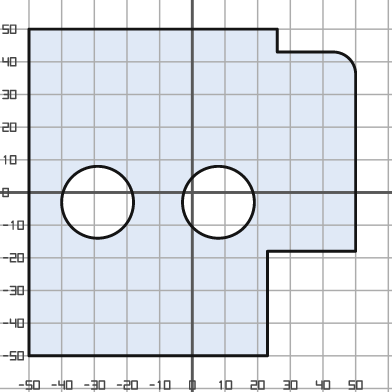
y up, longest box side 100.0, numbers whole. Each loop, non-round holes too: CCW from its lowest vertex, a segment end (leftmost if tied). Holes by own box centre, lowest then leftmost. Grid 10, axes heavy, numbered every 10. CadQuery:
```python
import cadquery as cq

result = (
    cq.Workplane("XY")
    .moveTo(-50.0, -50.0)
    .lineTo(23.0, -50.0)
    .lineTo(23.0, -18.0)
    .lineTo(50.0, -18.0)
    .lineTo(50.0, 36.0)
    .threePointArc((48.0, 41.0), (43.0, 43.0))
    .lineTo(26.0, 43.0)
    .lineTo(26.0, 50.0)
    .lineTo(-50.0, 50.0)
    .close()
    .moveTo(-29.0, -3.0)
    .circle(11.0)
    .moveTo(8.0, -3.0)
    .circle(11.0)
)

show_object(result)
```